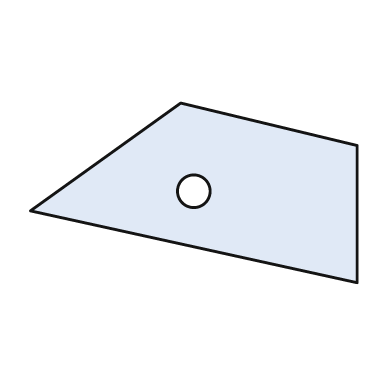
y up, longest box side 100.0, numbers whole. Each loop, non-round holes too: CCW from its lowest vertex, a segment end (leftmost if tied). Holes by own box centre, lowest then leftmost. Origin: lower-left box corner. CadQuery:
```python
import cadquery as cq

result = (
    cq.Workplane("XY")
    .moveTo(100.0, 0.0)
    .lineTo(100.0, 42.0)
    .lineTo(46.0, 55.0)
    .lineTo(0.0, 22.0)
    .close()
    .moveTo(50.0, 28.0)
    .circle(5.0)
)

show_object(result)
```